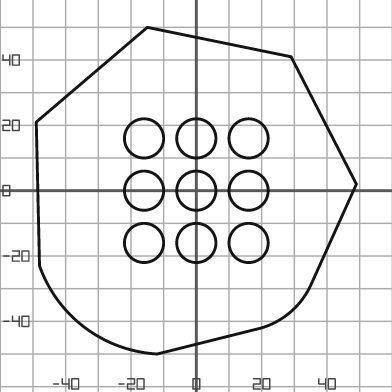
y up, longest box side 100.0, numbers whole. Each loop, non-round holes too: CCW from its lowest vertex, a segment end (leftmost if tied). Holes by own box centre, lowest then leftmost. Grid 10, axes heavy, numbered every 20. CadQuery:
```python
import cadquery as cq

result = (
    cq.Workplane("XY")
    .moveTo(-12.0, -50.0)
    .lineTo(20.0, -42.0)
    .threePointArc((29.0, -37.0), (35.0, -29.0))
    .lineTo(49.0, 2.0)
    .lineTo(29.0, 41.0)
    .lineTo(-15.0, 50.0)
    .lineTo(-49.0, 21.0)
    .lineTo(-48.0, -23.0)
    .threePointArc((-34.0, -42.0), (-12.0, -50.0))
    .close()
    .moveTo(-16.0, -16.0)
    .circle(6.0)
    .moveTo(0.0, -16.0)
    .circle(6.0)
    .moveTo(16.0, -16.0)
    .circle(6.0)
    .moveTo(-16.0, 0.0)
    .circle(6.0)
    .moveTo(0.0, 0.0)
    .circle(6.0)
    .moveTo(16.0, 0.0)
    .circle(6.0)
    .moveTo(-16.0, 16.0)
    .circle(6.0)
    .moveTo(0.0, 16.0)
    .circle(6.0)
    .moveTo(16.0, 16.0)
    .circle(6.0)
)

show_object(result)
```